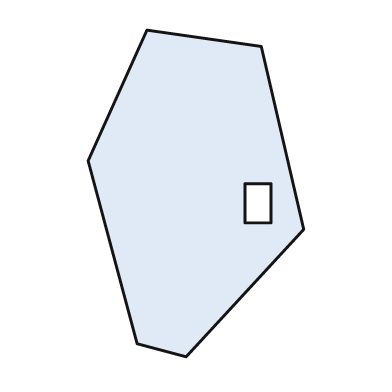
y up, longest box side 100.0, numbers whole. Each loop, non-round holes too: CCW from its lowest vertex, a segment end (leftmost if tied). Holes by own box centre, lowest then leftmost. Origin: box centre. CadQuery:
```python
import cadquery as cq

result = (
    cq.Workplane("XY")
    .moveTo(-3.0, -50.0)
    .lineTo(33.0, -11.0)
    .lineTo(20.0, 45.0)
    .lineTo(-15.0, 50.0)
    .lineTo(-33.0, 10.0)
    .lineTo(-18.0, -46.0)
    .close()
    .moveTo(15.0, -9.0)
    .lineTo(23.0, -9.0)
    .lineTo(23.0, 3.0)
    .lineTo(15.0, 3.0)
    .close()
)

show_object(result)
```